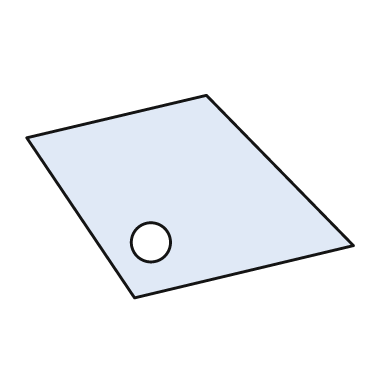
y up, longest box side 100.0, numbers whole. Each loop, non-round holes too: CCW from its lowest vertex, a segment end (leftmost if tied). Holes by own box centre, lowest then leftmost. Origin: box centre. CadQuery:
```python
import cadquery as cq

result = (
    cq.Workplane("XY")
    .moveTo(-17.0, -31.0)
    .lineTo(50.0, -15.0)
    .lineTo(5.0, 31.0)
    .lineTo(-50.0, 18.0)
    .close()
    .moveTo(-12.0, -14.0)
    .circle(6.0)
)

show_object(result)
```